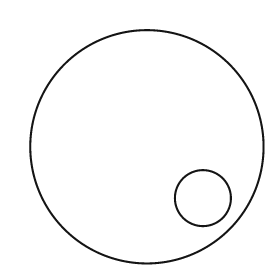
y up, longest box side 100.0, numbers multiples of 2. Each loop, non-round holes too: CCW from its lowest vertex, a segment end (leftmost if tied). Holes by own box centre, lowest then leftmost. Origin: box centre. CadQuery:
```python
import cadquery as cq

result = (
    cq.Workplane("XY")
    .moveTo(0.0, 0.0)
    .circle(50.0)
    .moveTo(24.0, -22.0)
    .circle(12.0)
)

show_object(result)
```